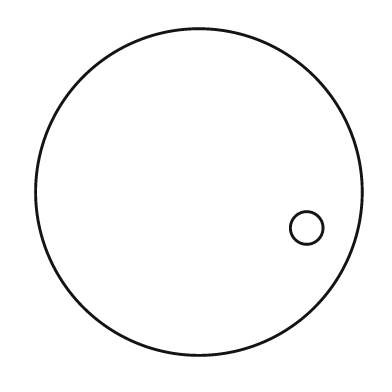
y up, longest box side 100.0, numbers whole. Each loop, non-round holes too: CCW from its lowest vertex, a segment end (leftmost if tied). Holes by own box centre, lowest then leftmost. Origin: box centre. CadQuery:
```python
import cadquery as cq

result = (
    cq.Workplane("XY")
    .moveTo(0.0, 0.0)
    .circle(50.0)
    .moveTo(33.0, -11.0)
    .circle(5.0)
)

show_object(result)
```